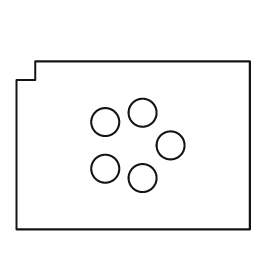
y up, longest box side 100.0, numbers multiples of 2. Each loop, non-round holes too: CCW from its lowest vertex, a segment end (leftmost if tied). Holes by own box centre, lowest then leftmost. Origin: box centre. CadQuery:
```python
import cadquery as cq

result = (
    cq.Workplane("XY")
    .moveTo(-50.0, -36.0)
    .lineTo(50.0, -36.0)
    .lineTo(50.0, 36.0)
    .lineTo(-42.0, 36.0)
    .lineTo(-42.0, 28.0)
    .lineTo(-50.0, 28.0)
    .close()
    .moveTo(4.0, -14.0)
    .circle(6.0)
    .moveTo(-12.0, -10.0)
    .circle(6.0)
    .moveTo(16.0, 0.0)
    .circle(6.0)
    .moveTo(-12.0, 10.0)
    .circle(6.0)
    .moveTo(4.0, 14.0)
    .circle(6.0)
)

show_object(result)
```